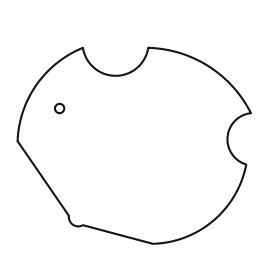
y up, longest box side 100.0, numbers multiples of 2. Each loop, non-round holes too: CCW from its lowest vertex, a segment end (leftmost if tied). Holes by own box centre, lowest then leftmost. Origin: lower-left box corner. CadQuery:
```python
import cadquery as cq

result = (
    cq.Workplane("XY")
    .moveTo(58.0, 0.0)
    .threePointArc((84.0, 10.0), (98.0, 34.0))
    .threePointArc((90.0, 46.0), (100.0, 56.0))
    .threePointArc((82.0, 76.0), (56.0, 84.0))
    .threePointArc((42.0, 72.0), (28.0, 84.0))
    .threePointArc((8.0, 68.0), (0.0, 44.0))
    .lineTo(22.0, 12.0)
    .threePointArc((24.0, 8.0), (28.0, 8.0))
    .close()
    .moveTo(18.0, 58.0)
    .circle(2.0)
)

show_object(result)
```